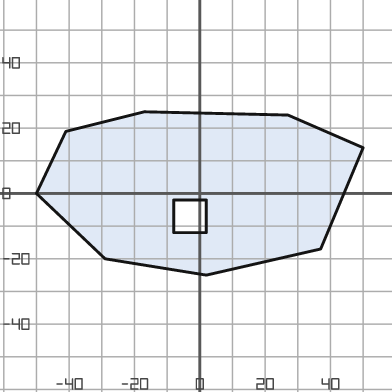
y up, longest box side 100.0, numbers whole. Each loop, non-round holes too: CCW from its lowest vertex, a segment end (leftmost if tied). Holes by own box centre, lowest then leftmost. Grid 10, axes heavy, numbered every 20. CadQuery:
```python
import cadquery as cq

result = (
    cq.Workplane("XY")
    .moveTo(2.0, -25.0)
    .lineTo(37.0, -17.0)
    .lineTo(50.0, 14.0)
    .lineTo(27.0, 24.0)
    .lineTo(-17.0, 25.0)
    .lineTo(-41.0, 19.0)
    .lineTo(-50.0, 0.0)
    .lineTo(-29.0, -20.0)
    .close()
    .moveTo(-8.0, -12.0)
    .lineTo(2.0, -12.0)
    .lineTo(2.0, -2.0)
    .lineTo(-8.0, -2.0)
    .close()
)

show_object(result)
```